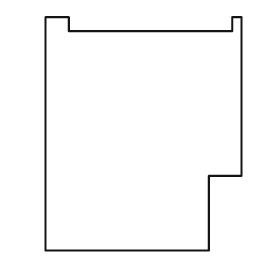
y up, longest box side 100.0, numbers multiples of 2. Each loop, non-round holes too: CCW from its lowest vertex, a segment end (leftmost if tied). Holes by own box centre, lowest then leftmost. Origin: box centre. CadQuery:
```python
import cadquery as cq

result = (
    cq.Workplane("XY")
    .moveTo(-42.0, -50.0)
    .lineTo(28.0, -50.0)
    .lineTo(28.0, -18.0)
    .lineTo(42.0, -18.0)
    .lineTo(42.0, 50.0)
    .lineTo(38.0, 50.0)
    .lineTo(38.0, 44.0)
    .lineTo(-32.0, 44.0)
    .lineTo(-32.0, 50.0)
    .lineTo(-42.0, 50.0)
    .close()
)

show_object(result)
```